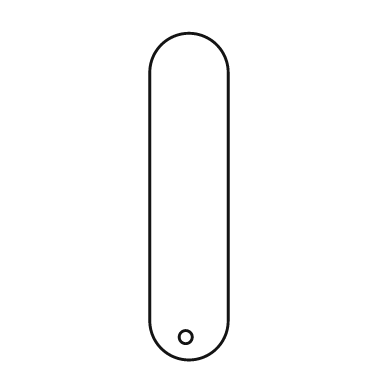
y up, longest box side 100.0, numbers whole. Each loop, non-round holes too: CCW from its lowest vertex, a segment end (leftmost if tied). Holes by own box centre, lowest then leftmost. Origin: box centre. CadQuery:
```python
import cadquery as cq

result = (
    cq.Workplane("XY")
    .moveTo(-12.0, -38.0)
    .threePointArc((0.0, -50.0), (12.0, -38.0))
    .lineTo(12.0, 38.0)
    .threePointArc((0.0, 50.0), (-12.0, 38.0))
    .close()
    .moveTo(-1.0, -43.0)
    .circle(2.0)
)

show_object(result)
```